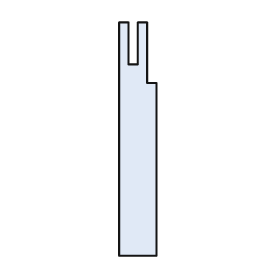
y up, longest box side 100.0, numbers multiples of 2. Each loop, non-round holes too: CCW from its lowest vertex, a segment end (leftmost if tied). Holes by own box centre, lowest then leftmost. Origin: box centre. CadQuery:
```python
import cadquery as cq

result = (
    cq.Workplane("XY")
    .moveTo(-8.0, -50.0)
    .lineTo(8.0, -50.0)
    .lineTo(8.0, 24.0)
    .lineTo(4.0, 24.0)
    .lineTo(4.0, 50.0)
    .lineTo(0.0, 50.0)
    .lineTo(0.0, 32.0)
    .lineTo(-4.0, 32.0)
    .lineTo(-4.0, 50.0)
    .lineTo(-8.0, 50.0)
    .close()
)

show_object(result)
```